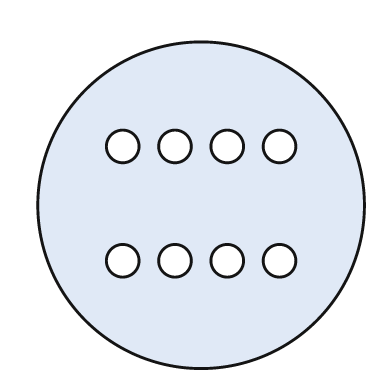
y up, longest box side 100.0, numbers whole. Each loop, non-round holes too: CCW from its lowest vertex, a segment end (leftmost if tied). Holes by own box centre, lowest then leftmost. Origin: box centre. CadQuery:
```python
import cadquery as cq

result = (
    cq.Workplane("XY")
    .moveTo(0.0, 0.0)
    .circle(50.0)
    .moveTo(-24.0, -17.0)
    .circle(5.0)
    .moveTo(-8.0, -17.0)
    .circle(5.0)
    .moveTo(8.0, -17.0)
    .circle(5.0)
    .moveTo(24.0, -17.0)
    .circle(5.0)
    .moveTo(-24.0, 18.0)
    .circle(5.0)
    .moveTo(-8.0, 18.0)
    .circle(5.0)
    .moveTo(8.0, 18.0)
    .circle(5.0)
    .moveTo(24.0, 18.0)
    .circle(5.0)
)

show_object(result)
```